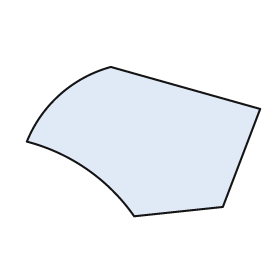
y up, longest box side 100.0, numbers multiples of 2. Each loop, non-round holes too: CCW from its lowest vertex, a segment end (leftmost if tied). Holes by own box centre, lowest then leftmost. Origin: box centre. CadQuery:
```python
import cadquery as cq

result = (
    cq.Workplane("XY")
    .moveTo(-4.0, -32.0)
    .lineTo(34.0, -28.0)
    .lineTo(50.0, 14.0)
    .lineTo(-14.0, 32.0)
    .threePointArc((-36.0, 20.0), (-50.0, 0.0))
    .threePointArc((-24.0, -12.0), (-4.0, -32.0))
    .close()
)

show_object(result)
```